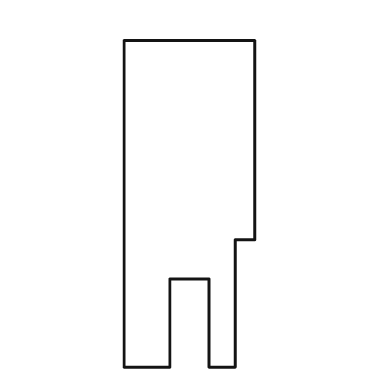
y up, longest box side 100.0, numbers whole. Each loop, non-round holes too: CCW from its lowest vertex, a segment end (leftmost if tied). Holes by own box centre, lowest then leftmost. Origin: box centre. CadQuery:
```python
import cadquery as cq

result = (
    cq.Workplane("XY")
    .moveTo(-20.0, -50.0)
    .lineTo(-6.0, -50.0)
    .lineTo(-6.0, -23.0)
    .lineTo(6.0, -23.0)
    .lineTo(6.0, -50.0)
    .lineTo(14.0, -50.0)
    .lineTo(14.0, -11.0)
    .lineTo(20.0, -11.0)
    .lineTo(20.0, 50.0)
    .lineTo(-20.0, 50.0)
    .close()
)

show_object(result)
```